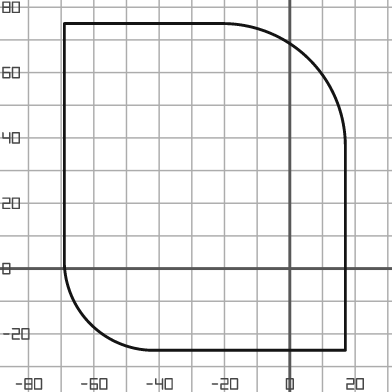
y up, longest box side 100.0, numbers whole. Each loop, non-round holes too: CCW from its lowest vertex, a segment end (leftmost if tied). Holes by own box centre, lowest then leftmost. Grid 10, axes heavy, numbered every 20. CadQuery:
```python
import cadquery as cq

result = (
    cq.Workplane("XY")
    .moveTo(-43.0, -25.0)
    .lineTo(17.0, -25.0)
    .lineTo(17.0, 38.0)
    .threePointArc((6.0, 64.0), (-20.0, 75.0))
    .lineTo(-69.0, 75.0)
    .lineTo(-69.0, 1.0)
    .threePointArc((-61.0, -17.0), (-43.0, -25.0))
    .close()
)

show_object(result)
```